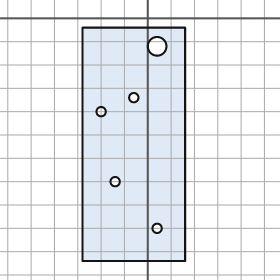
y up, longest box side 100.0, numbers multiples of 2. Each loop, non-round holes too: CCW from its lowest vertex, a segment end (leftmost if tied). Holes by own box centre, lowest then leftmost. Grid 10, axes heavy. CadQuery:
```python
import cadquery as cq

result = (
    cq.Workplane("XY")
    .moveTo(-28.0, -104.0)
    .lineTo(16.0, -104.0)
    .lineTo(16.0, -4.0)
    .lineTo(-28.0, -4.0)
    .close()
    .moveTo(4.0, -90.0)
    .circle(2.0)
    .moveTo(-14.0, -70.0)
    .circle(2.0)
    .moveTo(-20.0, -40.0)
    .circle(2.0)
    .moveTo(-6.0, -34.0)
    .circle(2.0)
    .moveTo(4.0, -12.0)
    .circle(4.0)
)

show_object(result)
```